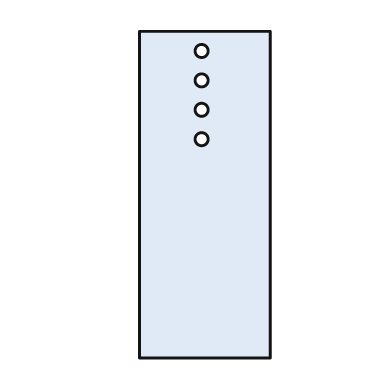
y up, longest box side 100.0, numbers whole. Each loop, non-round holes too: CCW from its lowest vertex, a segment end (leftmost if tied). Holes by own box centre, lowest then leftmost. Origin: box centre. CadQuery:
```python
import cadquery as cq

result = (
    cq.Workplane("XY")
    .moveTo(-20.0, -50.0)
    .lineTo(20.0, -50.0)
    .lineTo(20.0, 50.0)
    .lineTo(-20.0, 50.0)
    .close()
    .moveTo(-1.0, 17.0)
    .circle(2.0)
    .moveTo(-1.0, 26.0)
    .circle(2.0)
    .moveTo(-1.0, 35.0)
    .circle(2.0)
    .moveTo(-1.0, 44.0)
    .circle(2.0)
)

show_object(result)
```